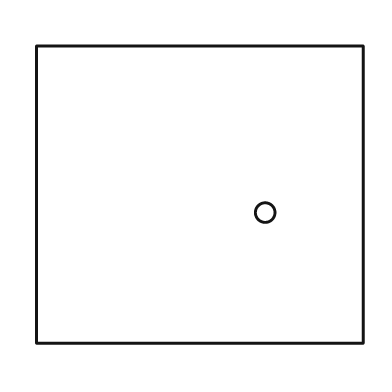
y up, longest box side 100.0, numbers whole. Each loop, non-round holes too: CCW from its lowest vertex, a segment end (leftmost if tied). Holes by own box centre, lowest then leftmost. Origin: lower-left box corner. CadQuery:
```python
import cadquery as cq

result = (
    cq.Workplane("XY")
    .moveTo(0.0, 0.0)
    .lineTo(100.0, 0.0)
    .lineTo(100.0, 91.0)
    .lineTo(0.0, 91.0)
    .close()
    .moveTo(70.0, 40.0)
    .circle(3.0)
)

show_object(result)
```